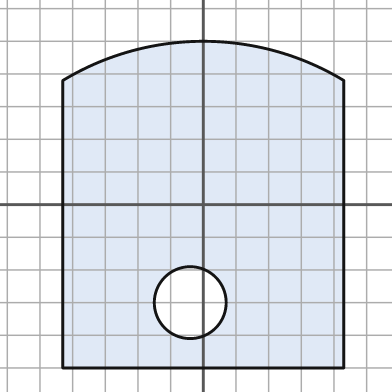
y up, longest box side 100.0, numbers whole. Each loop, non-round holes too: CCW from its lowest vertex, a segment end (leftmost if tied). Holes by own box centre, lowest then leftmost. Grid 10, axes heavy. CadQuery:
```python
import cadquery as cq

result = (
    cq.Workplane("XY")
    .moveTo(-43.0, -50.0)
    .lineTo(43.0, -50.0)
    .lineTo(43.0, 38.0)
    .threePointArc((0.0, 50.0), (-43.0, 38.0))
    .close()
    .moveTo(-4.0, -30.0)
    .circle(11.0)
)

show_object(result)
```